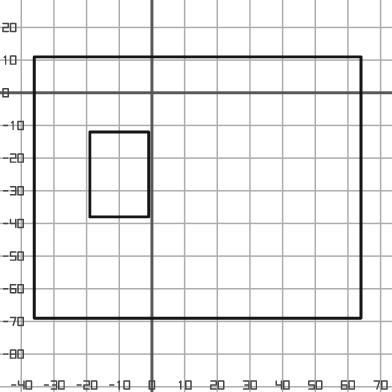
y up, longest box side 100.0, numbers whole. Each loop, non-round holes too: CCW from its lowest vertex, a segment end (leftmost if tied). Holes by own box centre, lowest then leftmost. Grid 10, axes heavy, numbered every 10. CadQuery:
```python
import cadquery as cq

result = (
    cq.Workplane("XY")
    .moveTo(-36.0, -69.0)
    .lineTo(64.0, -69.0)
    .lineTo(64.0, 11.0)
    .lineTo(-36.0, 11.0)
    .close()
    .moveTo(-19.0, -38.0)
    .lineTo(-1.0, -38.0)
    .lineTo(-1.0, -12.0)
    .lineTo(-19.0, -12.0)
    .close()
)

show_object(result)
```